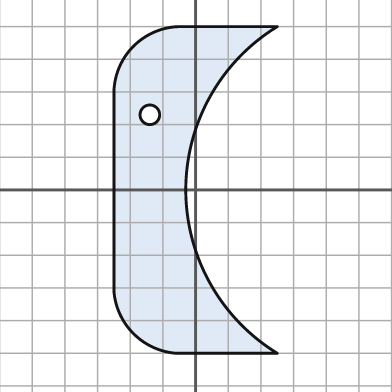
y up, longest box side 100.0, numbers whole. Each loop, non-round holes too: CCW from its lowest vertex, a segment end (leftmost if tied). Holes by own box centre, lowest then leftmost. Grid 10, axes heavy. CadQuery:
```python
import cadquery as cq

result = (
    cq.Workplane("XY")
    .moveTo(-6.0, -50.0)
    .lineTo(25.0, -50.0)
    .threePointArc((-3.0, 0.0), (25.0, 50.0))
    .lineTo(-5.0, 50.0)
    .threePointArc((-19.0, 44.0), (-25.0, 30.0))
    .lineTo(-25.0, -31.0)
    .threePointArc((-19.0, -44.0), (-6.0, -50.0))
    .close()
    .moveTo(-14.0, 23.0)
    .circle(3.0)
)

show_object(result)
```